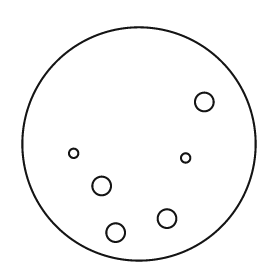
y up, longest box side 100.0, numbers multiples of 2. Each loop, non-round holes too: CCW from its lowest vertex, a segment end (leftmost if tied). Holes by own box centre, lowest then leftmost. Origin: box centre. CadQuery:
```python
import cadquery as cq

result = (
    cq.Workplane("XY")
    .moveTo(0.0, 0.0)
    .circle(50.0)
    .moveTo(-10.0, -38.0)
    .circle(4.0)
    .moveTo(12.0, -32.0)
    .circle(4.0)
    .moveTo(-16.0, -18.0)
    .circle(4.0)
    .moveTo(20.0, -6.0)
    .circle(2.0)
    .moveTo(-28.0, -4.0)
    .circle(2.0)
    .moveTo(28.0, 18.0)
    .circle(4.0)
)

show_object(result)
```